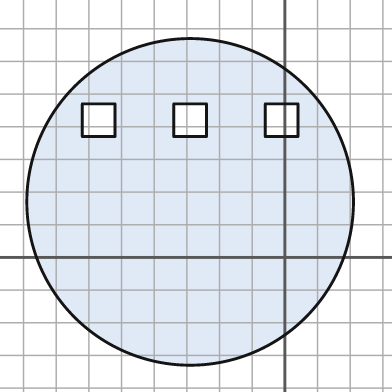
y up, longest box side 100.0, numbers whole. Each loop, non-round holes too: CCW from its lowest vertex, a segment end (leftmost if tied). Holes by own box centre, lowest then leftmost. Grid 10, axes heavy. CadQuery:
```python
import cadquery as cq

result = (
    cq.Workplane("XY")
    .moveTo(-29.0, 17.0)
    .circle(50.0)
    .moveTo(-62.0, 37.0)
    .lineTo(-52.0, 37.0)
    .lineTo(-52.0, 47.0)
    .lineTo(-62.0, 47.0)
    .close()
    .moveTo(-34.0, 37.0)
    .lineTo(-24.0, 37.0)
    .lineTo(-24.0, 47.0)
    .lineTo(-34.0, 47.0)
    .close()
    .moveTo(-6.0, 37.0)
    .lineTo(4.0, 37.0)
    .lineTo(4.0, 47.0)
    .lineTo(-6.0, 47.0)
    .close()
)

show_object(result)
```